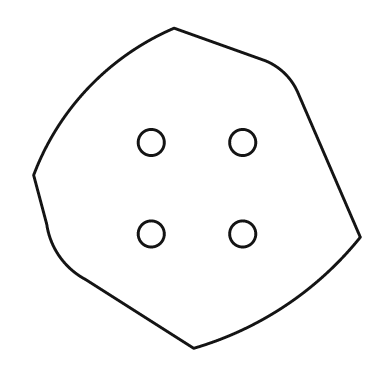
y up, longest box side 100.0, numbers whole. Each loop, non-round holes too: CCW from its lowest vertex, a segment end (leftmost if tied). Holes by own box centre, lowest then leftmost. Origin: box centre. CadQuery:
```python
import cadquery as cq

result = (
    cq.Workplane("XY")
    .moveTo(-1.0, -49.0)
    .threePointArc((27.0, -36.0), (50.0, -15.0))
    .lineTo(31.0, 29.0)
    .threePointArc((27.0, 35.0), (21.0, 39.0))
    .lineTo(-7.0, 49.0)
    .threePointArc((-33.0, 31.0), (-50.0, 4.0))
    .lineTo(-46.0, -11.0)
    .threePointArc((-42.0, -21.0), (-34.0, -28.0))
    .close()
    .moveTo(-14.0, -14.0)
    .circle(4.0)
    .moveTo(14.0, -14.0)
    .circle(4.0)
    .moveTo(-14.0, 14.0)
    .circle(4.0)
    .moveTo(14.0, 14.0)
    .circle(4.0)
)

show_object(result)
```